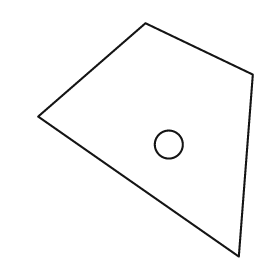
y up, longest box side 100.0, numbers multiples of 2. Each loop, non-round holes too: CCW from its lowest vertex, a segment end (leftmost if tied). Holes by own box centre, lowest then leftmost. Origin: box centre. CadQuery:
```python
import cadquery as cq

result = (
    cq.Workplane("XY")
    .moveTo(40.0, -50.0)
    .lineTo(46.0, 28.0)
    .lineTo(0.0, 50.0)
    .lineTo(-46.0, 10.0)
    .close()
    .moveTo(10.0, -2.0)
    .circle(6.0)
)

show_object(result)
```